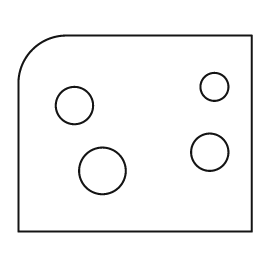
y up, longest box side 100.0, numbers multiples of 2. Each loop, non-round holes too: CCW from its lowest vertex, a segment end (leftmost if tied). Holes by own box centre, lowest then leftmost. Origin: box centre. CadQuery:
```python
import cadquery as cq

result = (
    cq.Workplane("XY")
    .moveTo(-50.0, -42.0)
    .lineTo(50.0, -42.0)
    .lineTo(50.0, 42.0)
    .lineTo(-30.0, 42.0)
    .threePointArc((-44.0, 36.0), (-50.0, 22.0))
    .close()
    .moveTo(-14.0, -16.0)
    .circle(10.0)
    .moveTo(32.0, -8.0)
    .circle(8.0)
    .moveTo(-26.0, 12.0)
    .circle(8.0)
    .moveTo(34.0, 20.0)
    .circle(6.0)
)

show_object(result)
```